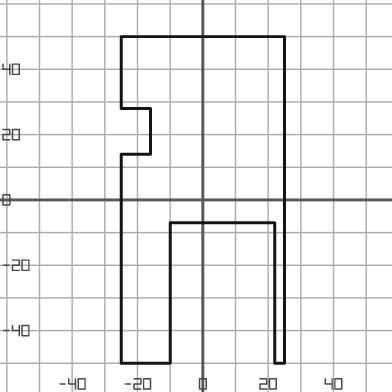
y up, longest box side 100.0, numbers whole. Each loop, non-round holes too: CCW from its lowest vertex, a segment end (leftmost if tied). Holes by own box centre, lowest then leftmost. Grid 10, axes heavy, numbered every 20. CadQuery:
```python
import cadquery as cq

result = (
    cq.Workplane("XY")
    .moveTo(-25.0, -50.0)
    .lineTo(-10.0, -50.0)
    .lineTo(-10.0, -7.0)
    .lineTo(22.0, -7.0)
    .lineTo(22.0, -50.0)
    .lineTo(25.0, -50.0)
    .lineTo(25.0, 50.0)
    .lineTo(-25.0, 50.0)
    .lineTo(-25.0, 28.0)
    .lineTo(-16.0, 28.0)
    .lineTo(-16.0, 14.0)
    .lineTo(-25.0, 14.0)
    .close()
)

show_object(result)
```